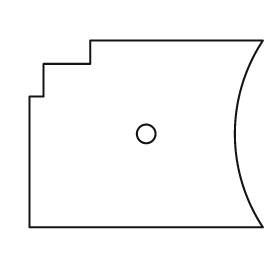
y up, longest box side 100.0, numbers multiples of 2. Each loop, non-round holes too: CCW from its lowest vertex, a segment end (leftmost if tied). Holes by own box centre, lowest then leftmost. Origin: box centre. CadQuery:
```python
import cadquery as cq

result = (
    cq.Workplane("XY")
    .moveTo(-50.0, -40.0)
    .lineTo(50.0, -40.0)
    .threePointArc((38.0, 0.0), (50.0, 40.0))
    .lineTo(-24.0, 40.0)
    .lineTo(-24.0, 30.0)
    .lineTo(-44.0, 30.0)
    .lineTo(-44.0, 16.0)
    .lineTo(-50.0, 16.0)
    .close()
    .moveTo(0.0, 0.0)
    .circle(4.0)
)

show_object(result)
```